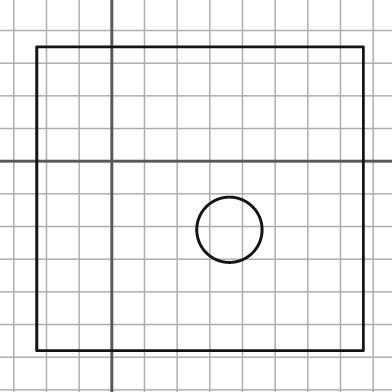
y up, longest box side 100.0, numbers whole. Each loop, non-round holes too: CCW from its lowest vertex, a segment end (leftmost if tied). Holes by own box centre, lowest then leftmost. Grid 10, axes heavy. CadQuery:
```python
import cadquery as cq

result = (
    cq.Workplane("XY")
    .moveTo(-23.0, -58.0)
    .lineTo(77.0, -58.0)
    .lineTo(77.0, 35.0)
    .lineTo(-23.0, 35.0)
    .close()
    .moveTo(36.0, -21.0)
    .circle(10.0)
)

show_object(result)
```